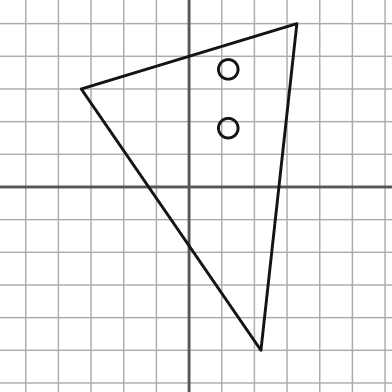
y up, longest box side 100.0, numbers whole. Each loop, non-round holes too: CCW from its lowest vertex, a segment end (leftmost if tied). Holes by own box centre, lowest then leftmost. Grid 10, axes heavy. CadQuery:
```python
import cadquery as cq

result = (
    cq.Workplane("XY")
    .moveTo(22.0, -50.0)
    .lineTo(33.0, 50.0)
    .lineTo(-33.0, 30.0)
    .close()
    .moveTo(12.0, 18.0)
    .circle(3.0)
    .moveTo(12.0, 36.0)
    .circle(3.0)
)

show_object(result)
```